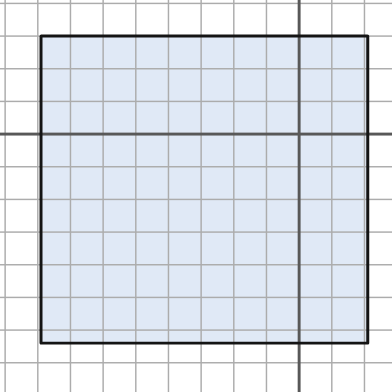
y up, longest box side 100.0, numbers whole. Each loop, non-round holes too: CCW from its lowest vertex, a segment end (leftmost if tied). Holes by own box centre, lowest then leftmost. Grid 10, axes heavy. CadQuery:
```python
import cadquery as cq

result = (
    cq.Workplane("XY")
    .moveTo(-79.0, -64.0)
    .lineTo(21.0, -64.0)
    .lineTo(21.0, 30.0)
    .lineTo(-79.0, 30.0)
    .close()
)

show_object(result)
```